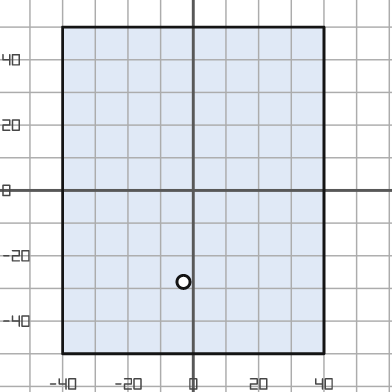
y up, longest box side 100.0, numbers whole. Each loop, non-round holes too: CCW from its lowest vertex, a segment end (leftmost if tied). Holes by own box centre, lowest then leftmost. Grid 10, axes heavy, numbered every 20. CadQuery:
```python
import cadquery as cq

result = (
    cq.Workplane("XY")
    .moveTo(-40.0, -50.0)
    .lineTo(40.0, -50.0)
    .lineTo(40.0, 50.0)
    .lineTo(-40.0, 50.0)
    .close()
    .moveTo(-3.0, -28.0)
    .circle(2.0)
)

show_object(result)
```